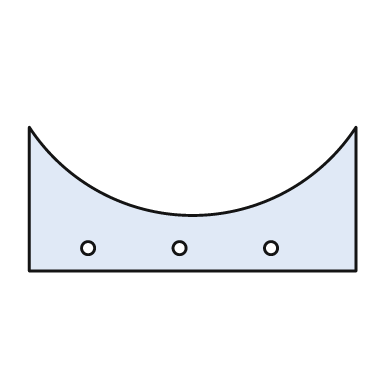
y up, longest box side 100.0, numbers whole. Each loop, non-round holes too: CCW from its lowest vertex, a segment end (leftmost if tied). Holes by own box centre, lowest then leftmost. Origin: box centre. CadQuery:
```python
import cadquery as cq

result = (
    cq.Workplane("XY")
    .moveTo(-50.0, -22.0)
    .lineTo(50.0, -22.0)
    .lineTo(50.0, 22.0)
    .threePointArc((0.0, -5.0), (-50.0, 22.0))
    .close()
    .moveTo(-32.0, -15.0)
    .circle(2.0)
    .moveTo(-4.0, -15.0)
    .circle(2.0)
    .moveTo(24.0, -15.0)
    .circle(2.0)
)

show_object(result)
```